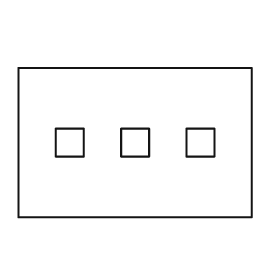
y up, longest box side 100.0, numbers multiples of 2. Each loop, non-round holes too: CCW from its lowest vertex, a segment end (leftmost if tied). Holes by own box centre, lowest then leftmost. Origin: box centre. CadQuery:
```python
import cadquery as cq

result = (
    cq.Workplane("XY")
    .moveTo(-50.0, -32.0)
    .lineTo(50.0, -32.0)
    .lineTo(50.0, 32.0)
    .lineTo(-50.0, 32.0)
    .close()
    .moveTo(-34.0, -6.0)
    .lineTo(-22.0, -6.0)
    .lineTo(-22.0, 6.0)
    .lineTo(-34.0, 6.0)
    .close()
    .moveTo(-6.0, -6.0)
    .lineTo(6.0, -6.0)
    .lineTo(6.0, 6.0)
    .lineTo(-6.0, 6.0)
    .close()
    .moveTo(22.0, -6.0)
    .lineTo(34.0, -6.0)
    .lineTo(34.0, 6.0)
    .lineTo(22.0, 6.0)
    .close()
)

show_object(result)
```